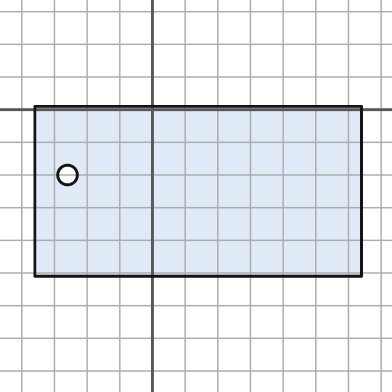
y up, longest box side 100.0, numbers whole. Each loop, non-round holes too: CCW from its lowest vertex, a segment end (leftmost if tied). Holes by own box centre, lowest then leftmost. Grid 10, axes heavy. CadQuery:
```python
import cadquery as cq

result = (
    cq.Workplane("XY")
    .moveTo(-36.0, -51.0)
    .lineTo(64.0, -51.0)
    .lineTo(64.0, 1.0)
    .lineTo(-36.0, 1.0)
    .close()
    .moveTo(-26.0, -20.0)
    .circle(3.0)
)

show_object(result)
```